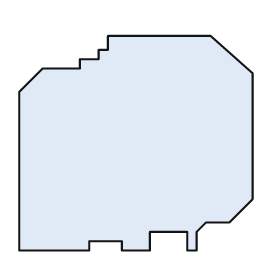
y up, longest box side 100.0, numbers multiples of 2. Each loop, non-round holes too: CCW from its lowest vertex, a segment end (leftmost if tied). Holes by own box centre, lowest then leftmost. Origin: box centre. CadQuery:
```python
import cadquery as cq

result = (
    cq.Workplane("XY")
    .moveTo(-50.0, -46.0)
    .lineTo(-20.0, -46.0)
    .lineTo(-20.0, -42.0)
    .lineTo(-6.0, -42.0)
    .lineTo(-6.0, -46.0)
    .lineTo(6.0, -46.0)
    .lineTo(6.0, -38.0)
    .lineTo(22.0, -38.0)
    .lineTo(22.0, -46.0)
    .lineTo(26.0, -46.0)
    .lineTo(26.0, -38.0)
    .lineTo(30.0, -34.0)
    .lineTo(40.0, -34.0)
    .lineTo(50.0, -24.0)
    .lineTo(50.0, 30.0)
    .lineTo(32.0, 46.0)
    .lineTo(-12.0, 46.0)
    .lineTo(-12.0, 40.0)
    .lineTo(-16.0, 40.0)
    .lineTo(-16.0, 36.0)
    .lineTo(-24.0, 36.0)
    .lineTo(-24.0, 32.0)
    .lineTo(-40.0, 32.0)
    .lineTo(-50.0, 22.0)
    .close()
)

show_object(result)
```